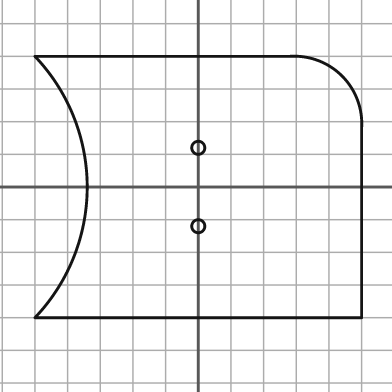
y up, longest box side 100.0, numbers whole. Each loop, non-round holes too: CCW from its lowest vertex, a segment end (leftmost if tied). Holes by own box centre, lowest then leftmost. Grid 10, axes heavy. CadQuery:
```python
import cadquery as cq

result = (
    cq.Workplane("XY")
    .moveTo(-50.0, -40.0)
    .lineTo(50.0, -40.0)
    .lineTo(50.0, 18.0)
    .threePointArc((44.0, 34.0), (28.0, 40.0))
    .lineTo(-50.0, 40.0)
    .threePointArc((-34.0, 0.0), (-50.0, -40.0))
    .close()
    .moveTo(0.0, -12.0)
    .circle(2.0)
    .moveTo(0.0, 12.0)
    .circle(2.0)
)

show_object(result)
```